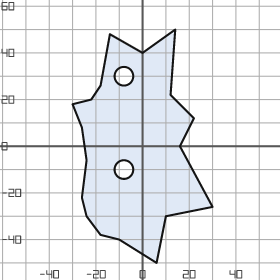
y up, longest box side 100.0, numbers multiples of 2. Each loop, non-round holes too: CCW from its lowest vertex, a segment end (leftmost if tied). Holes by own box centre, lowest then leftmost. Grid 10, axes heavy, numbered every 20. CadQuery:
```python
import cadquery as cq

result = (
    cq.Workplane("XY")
    .moveTo(6.0, -50.0)
    .lineTo(10.0, -30.0)
    .lineTo(30.0, -26.0)
    .lineTo(16.0, 0.0)
    .lineTo(22.0, 12.0)
    .lineTo(12.0, 22.0)
    .lineTo(14.0, 50.0)
    .lineTo(0.0, 40.0)
    .lineTo(-14.0, 48.0)
    .lineTo(-18.0, 26.0)
    .lineTo(-22.0, 20.0)
    .lineTo(-30.0, 18.0)
    .lineTo(-26.0, 8.0)
    .lineTo(-24.0, -6.0)
    .lineTo(-26.0, -22.0)
    .lineTo(-24.0, -30.0)
    .lineTo(-18.0, -38.0)
    .lineTo(-10.0, -40.0)
    .close()
    .moveTo(-8.0, -10.0)
    .circle(4.0)
    .moveTo(-8.0, 30.0)
    .circle(4.0)
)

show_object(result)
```